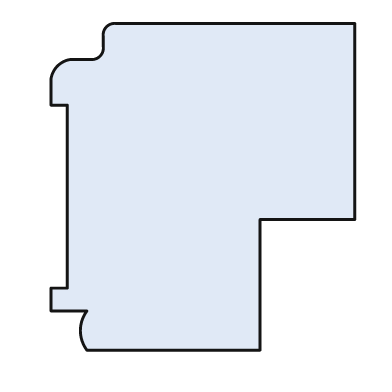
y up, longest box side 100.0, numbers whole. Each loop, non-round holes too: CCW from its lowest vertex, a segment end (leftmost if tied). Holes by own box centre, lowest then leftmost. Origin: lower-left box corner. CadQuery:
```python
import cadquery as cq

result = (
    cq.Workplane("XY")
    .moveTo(11.0, 0.0)
    .lineTo(64.0, 0.0)
    .lineTo(64.0, 40.0)
    .lineTo(93.0, 40.0)
    .lineTo(93.0, 100.0)
    .lineTo(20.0, 100.0)
    .threePointArc((17.0, 99.0), (16.0, 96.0))
    .lineTo(16.0, 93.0)
    .threePointArc((15.0, 90.0), (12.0, 89.0))
    .lineTo(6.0, 89.0)
    .threePointArc((2.0, 87.0), (0.0, 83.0))
    .lineTo(0.0, 75.0)
    .lineTo(5.0, 75.0)
    .lineTo(5.0, 19.0)
    .lineTo(0.0, 19.0)
    .lineTo(0.0, 12.0)
    .lineTo(11.0, 12.0)
    .threePointArc((9.0, 6.0), (11.0, 0.0))
    .close()
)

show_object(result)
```